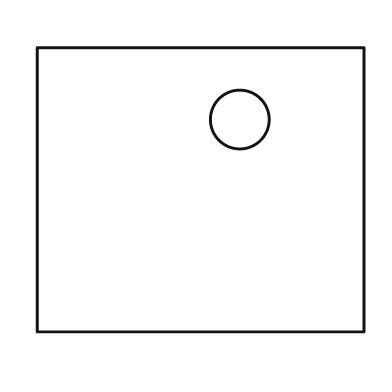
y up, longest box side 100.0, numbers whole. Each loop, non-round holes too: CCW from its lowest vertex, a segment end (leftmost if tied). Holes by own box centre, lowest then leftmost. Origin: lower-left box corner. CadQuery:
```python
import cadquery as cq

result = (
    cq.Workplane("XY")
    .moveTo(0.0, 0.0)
    .lineTo(100.0, 0.0)
    .lineTo(100.0, 87.0)
    .lineTo(0.0, 87.0)
    .close()
    .moveTo(62.0, 65.0)
    .circle(9.0)
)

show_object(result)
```